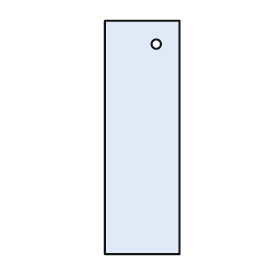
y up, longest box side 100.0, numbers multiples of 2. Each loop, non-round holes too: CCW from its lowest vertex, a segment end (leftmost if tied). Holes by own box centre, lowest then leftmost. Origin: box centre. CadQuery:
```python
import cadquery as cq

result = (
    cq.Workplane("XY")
    .moveTo(-16.0, -50.0)
    .lineTo(16.0, -50.0)
    .lineTo(16.0, 50.0)
    .lineTo(-16.0, 50.0)
    .close()
    .moveTo(6.0, 40.0)
    .circle(2.0)
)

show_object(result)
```